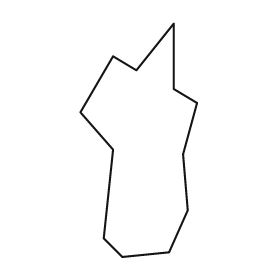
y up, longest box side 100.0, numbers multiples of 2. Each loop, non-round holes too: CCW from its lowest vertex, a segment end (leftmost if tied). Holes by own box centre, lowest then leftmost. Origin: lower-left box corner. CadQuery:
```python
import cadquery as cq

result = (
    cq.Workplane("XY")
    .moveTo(18.0, 0.0)
    .lineTo(38.0, 2.0)
    .lineTo(46.0, 20.0)
    .lineTo(44.0, 44.0)
    .lineTo(50.0, 66.0)
    .lineTo(40.0, 72.0)
    .lineTo(40.0, 100.0)
    .lineTo(24.0, 80.0)
    .lineTo(14.0, 86.0)
    .lineTo(0.0, 62.0)
    .lineTo(14.0, 46.0)
    .lineTo(10.0, 8.0)
    .close()
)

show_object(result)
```